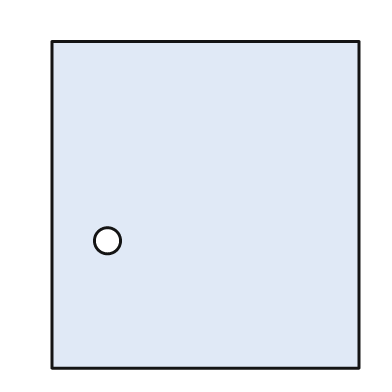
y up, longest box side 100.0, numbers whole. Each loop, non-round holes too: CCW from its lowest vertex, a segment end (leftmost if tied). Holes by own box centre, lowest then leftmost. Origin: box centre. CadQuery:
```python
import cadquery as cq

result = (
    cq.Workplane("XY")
    .moveTo(-47.0, -50.0)
    .lineTo(47.0, -50.0)
    .lineTo(47.0, 50.0)
    .lineTo(-47.0, 50.0)
    .close()
    .moveTo(-30.0, -11.0)
    .circle(4.0)
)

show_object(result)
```